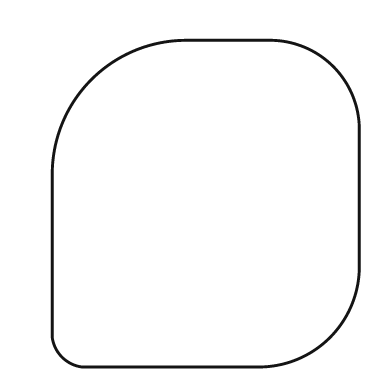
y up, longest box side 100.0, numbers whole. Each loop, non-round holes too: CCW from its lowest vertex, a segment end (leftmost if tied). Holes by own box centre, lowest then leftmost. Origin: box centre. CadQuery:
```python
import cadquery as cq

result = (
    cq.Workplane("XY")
    .moveTo(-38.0, -50.0)
    .lineTo(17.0, -50.0)
    .threePointArc((38.0, -41.0), (47.0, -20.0))
    .lineTo(47.0, 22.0)
    .threePointArc((39.0, 42.0), (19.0, 50.0))
    .lineTo(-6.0, 50.0)
    .threePointArc((-35.0, 38.0), (-47.0, 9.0))
    .lineTo(-47.0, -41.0)
    .threePointArc((-44.0, -47.0), (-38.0, -50.0))
    .close()
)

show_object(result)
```